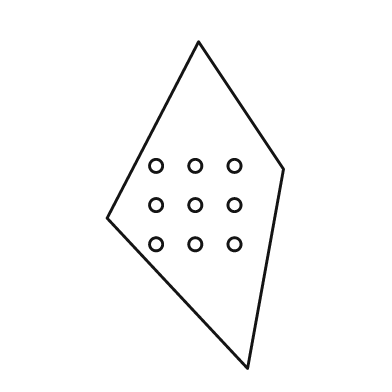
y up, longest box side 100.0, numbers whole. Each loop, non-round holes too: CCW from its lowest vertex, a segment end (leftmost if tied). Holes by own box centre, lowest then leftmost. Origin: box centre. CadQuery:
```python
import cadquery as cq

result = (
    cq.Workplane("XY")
    .moveTo(16.0, -50.0)
    .lineTo(27.0, 11.0)
    .lineTo(1.0, 50.0)
    .lineTo(-27.0, -4.0)
    .close()
    .moveTo(-12.0, -12.0)
    .circle(2.0)
    .moveTo(0.0, -12.0)
    .circle(2.0)
    .moveTo(12.0, -12.0)
    .circle(2.0)
    .moveTo(-12.0, 0.0)
    .circle(2.0)
    .moveTo(0.0, 0.0)
    .circle(2.0)
    .moveTo(12.0, 0.0)
    .circle(2.0)
    .moveTo(-12.0, 12.0)
    .circle(2.0)
    .moveTo(0.0, 12.0)
    .circle(2.0)
    .moveTo(12.0, 12.0)
    .circle(2.0)
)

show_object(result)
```